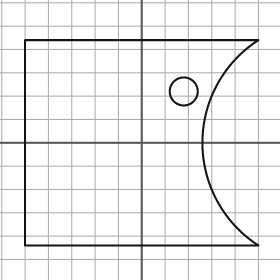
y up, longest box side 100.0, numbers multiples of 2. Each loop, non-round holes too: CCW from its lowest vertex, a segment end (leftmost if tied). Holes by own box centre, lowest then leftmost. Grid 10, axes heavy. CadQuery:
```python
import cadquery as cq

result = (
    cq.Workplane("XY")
    .moveTo(-50.0, -44.0)
    .lineTo(50.0, -44.0)
    .threePointArc((26.0, 0.0), (50.0, 44.0))
    .lineTo(-50.0, 44.0)
    .close()
    .moveTo(18.0, 22.0)
    .circle(6.0)
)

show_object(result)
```